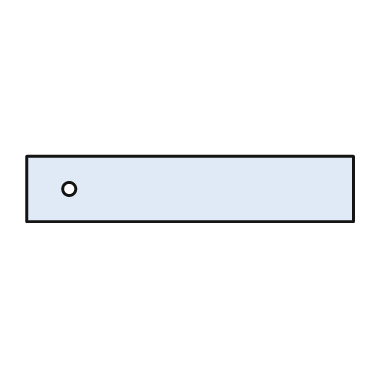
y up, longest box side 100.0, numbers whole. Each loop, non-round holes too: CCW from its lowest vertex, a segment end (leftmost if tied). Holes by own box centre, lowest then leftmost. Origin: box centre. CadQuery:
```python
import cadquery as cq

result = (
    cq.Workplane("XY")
    .moveTo(-50.0, -10.0)
    .lineTo(50.0, -10.0)
    .lineTo(50.0, 10.0)
    .lineTo(-50.0, 10.0)
    .close()
    .moveTo(-37.0, 0.0)
    .circle(2.0)
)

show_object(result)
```